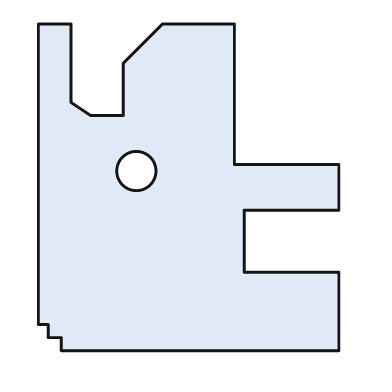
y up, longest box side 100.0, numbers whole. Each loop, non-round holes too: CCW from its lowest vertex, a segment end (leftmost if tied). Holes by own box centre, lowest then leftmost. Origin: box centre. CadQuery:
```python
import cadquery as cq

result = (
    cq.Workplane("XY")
    .moveTo(-39.0, -50.0)
    .lineTo(46.0, -50.0)
    .lineTo(46.0, -26.0)
    .lineTo(17.0, -26.0)
    .lineTo(17.0, -7.0)
    .lineTo(46.0, -7.0)
    .lineTo(46.0, 7.0)
    .lineTo(14.0, 7.0)
    .lineTo(14.0, 50.0)
    .lineTo(-8.0, 50.0)
    .lineTo(-20.0, 38.0)
    .lineTo(-20.0, 22.0)
    .lineTo(-30.0, 22.0)
    .lineTo(-36.0, 26.0)
    .lineTo(-36.0, 50.0)
    .lineTo(-46.0, 50.0)
    .lineTo(-46.0, -42.0)
    .lineTo(-43.0, -42.0)
    .lineTo(-43.0, -46.0)
    .lineTo(-39.0, -46.0)
    .close()
    .moveTo(-16.0, 5.0)
    .circle(6.0)
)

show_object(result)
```